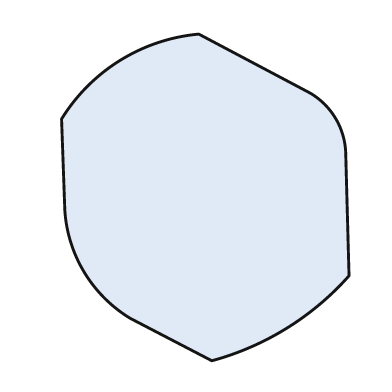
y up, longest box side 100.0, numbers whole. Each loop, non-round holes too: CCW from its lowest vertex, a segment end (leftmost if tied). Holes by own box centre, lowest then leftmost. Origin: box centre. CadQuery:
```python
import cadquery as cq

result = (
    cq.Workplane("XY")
    .moveTo(2.0, -50.0)
    .threePointArc((25.0, -40.0), (44.0, -24.0))
    .lineTo(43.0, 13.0)
    .threePointArc((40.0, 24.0), (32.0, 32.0))
    .lineTo(-2.0, 50.0)
    .threePointArc((-26.0, 42.0), (-44.0, 24.0))
    .lineTo(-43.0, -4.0)
    .threePointArc((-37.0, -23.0), (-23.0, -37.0))
    .close()
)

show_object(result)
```